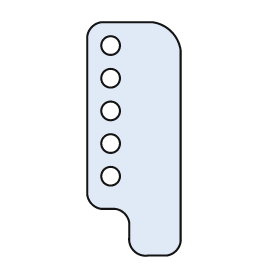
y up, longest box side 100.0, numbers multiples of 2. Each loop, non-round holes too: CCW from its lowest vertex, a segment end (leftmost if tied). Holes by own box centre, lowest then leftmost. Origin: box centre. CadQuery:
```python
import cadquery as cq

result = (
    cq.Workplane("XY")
    .moveTo(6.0, -50.0)
    .lineTo(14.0, -50.0)
    .threePointArc((18.0, -48.0), (20.0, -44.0))
    .lineTo(20.0, 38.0)
    .threePointArc((16.0, 46.0), (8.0, 50.0))
    .lineTo(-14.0, 50.0)
    .threePointArc((-18.0, 48.0), (-20.0, 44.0))
    .lineTo(-20.0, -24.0)
    .threePointArc((-18.0, -28.0), (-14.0, -30.0))
    .lineTo(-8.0, -30.0)
    .threePointArc((-4.0, -32.0), (-2.0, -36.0))
    .lineTo(-2.0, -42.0)
    .threePointArc((0.0, -48.0), (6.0, -50.0))
    .close()
    .moveTo(-10.0, -16.0)
    .circle(4.0)
    .moveTo(-10.0, -2.0)
    .circle(4.0)
    .moveTo(-10.0, 12.0)
    .circle(4.0)
    .moveTo(-10.0, 26.0)
    .circle(4.0)
    .moveTo(-10.0, 40.0)
    .circle(4.0)
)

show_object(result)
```